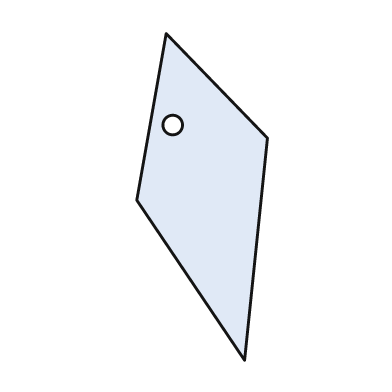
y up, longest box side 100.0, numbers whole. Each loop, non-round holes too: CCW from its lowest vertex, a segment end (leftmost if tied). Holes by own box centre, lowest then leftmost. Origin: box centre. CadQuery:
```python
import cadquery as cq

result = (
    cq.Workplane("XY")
    .moveTo(13.0, -50.0)
    .lineTo(20.0, 18.0)
    .lineTo(-11.0, 50.0)
    .lineTo(-20.0, -1.0)
    .close()
    .moveTo(-9.0, 22.0)
    .circle(3.0)
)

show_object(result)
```